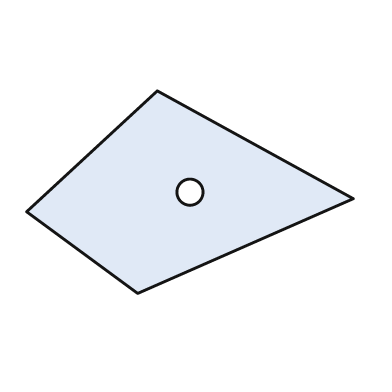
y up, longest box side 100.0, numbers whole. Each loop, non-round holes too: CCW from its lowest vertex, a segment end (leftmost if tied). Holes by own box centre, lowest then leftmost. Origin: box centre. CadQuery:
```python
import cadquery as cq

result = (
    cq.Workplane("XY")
    .moveTo(-16.0, -31.0)
    .lineTo(50.0, -2.0)
    .lineTo(-10.0, 31.0)
    .lineTo(-50.0, -6.0)
    .close()
    .moveTo(0.0, 0.0)
    .circle(4.0)
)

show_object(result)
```